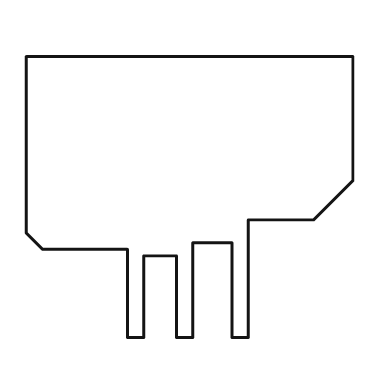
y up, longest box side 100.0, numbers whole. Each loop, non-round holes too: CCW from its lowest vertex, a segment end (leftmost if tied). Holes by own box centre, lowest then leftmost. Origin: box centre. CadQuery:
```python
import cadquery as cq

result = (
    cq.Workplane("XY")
    .moveTo(-19.0, -43.0)
    .lineTo(-14.0, -43.0)
    .lineTo(-14.0, -18.0)
    .lineTo(-4.0, -18.0)
    .lineTo(-4.0, -43.0)
    .lineTo(1.0, -43.0)
    .lineTo(1.0, -14.0)
    .lineTo(13.0, -14.0)
    .lineTo(13.0, -43.0)
    .lineTo(18.0, -43.0)
    .lineTo(18.0, -7.0)
    .lineTo(38.0, -7.0)
    .lineTo(50.0, 5.0)
    .lineTo(50.0, 43.0)
    .lineTo(-50.0, 43.0)
    .lineTo(-50.0, -11.0)
    .lineTo(-45.0, -16.0)
    .lineTo(-19.0, -16.0)
    .close()
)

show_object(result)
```